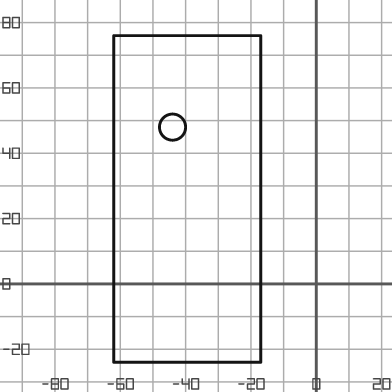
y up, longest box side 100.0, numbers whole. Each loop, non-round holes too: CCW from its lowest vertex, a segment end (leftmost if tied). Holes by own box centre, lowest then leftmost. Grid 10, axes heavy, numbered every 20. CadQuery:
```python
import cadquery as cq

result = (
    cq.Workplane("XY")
    .moveTo(-62.0, -24.0)
    .lineTo(-17.0, -24.0)
    .lineTo(-17.0, 76.0)
    .lineTo(-62.0, 76.0)
    .close()
    .moveTo(-44.0, 48.0)
    .circle(4.0)
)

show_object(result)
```